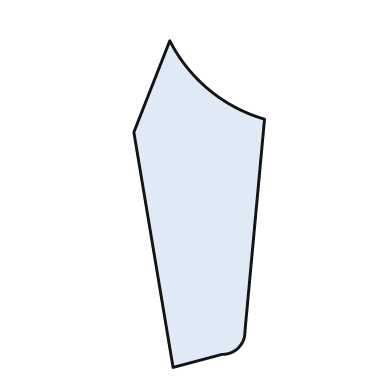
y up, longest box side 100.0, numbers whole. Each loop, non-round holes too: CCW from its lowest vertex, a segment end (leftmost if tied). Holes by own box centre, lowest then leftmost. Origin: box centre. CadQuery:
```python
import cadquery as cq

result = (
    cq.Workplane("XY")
    .moveTo(-8.0, -50.0)
    .lineTo(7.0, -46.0)
    .threePointArc((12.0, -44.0), (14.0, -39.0))
    .lineTo(20.0, 26.0)
    .threePointArc((3.0, 35.0), (-9.0, 50.0))
    .lineTo(-20.0, 22.0)
    .close()
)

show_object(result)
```